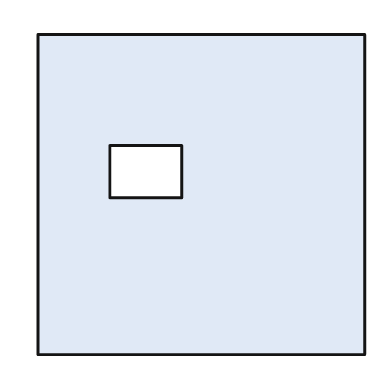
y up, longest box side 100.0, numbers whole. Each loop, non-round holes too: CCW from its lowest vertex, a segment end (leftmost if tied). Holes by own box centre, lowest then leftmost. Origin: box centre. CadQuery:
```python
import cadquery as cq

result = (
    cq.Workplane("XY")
    .moveTo(-50.0, -49.0)
    .lineTo(50.0, -49.0)
    .lineTo(50.0, 49.0)
    .lineTo(-50.0, 49.0)
    .close()
    .moveTo(-28.0, -1.0)
    .lineTo(-6.0, -1.0)
    .lineTo(-6.0, 15.0)
    .lineTo(-28.0, 15.0)
    .close()
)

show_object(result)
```